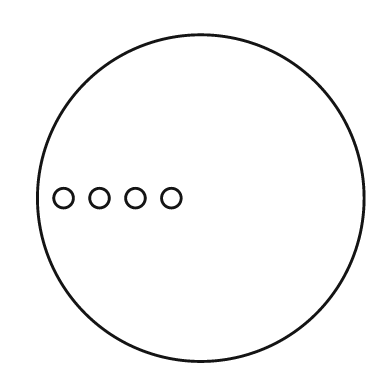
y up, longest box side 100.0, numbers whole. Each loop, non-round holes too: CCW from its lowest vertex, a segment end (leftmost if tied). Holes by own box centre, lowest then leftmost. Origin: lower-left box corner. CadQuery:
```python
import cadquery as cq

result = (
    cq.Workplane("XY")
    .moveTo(50.0, 50.0)
    .circle(50.0)
    .moveTo(8.0, 50.0)
    .circle(3.0)
    .moveTo(19.0, 50.0)
    .circle(3.0)
    .moveTo(30.0, 50.0)
    .circle(3.0)
    .moveTo(41.0, 50.0)
    .circle(3.0)
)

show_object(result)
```